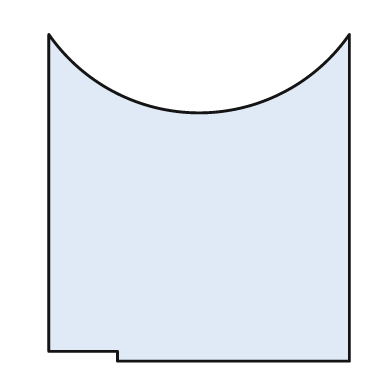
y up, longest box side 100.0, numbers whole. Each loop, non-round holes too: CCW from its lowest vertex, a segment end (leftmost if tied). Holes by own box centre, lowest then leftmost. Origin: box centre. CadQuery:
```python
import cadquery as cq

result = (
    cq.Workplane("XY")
    .moveTo(-25.0, -50.0)
    .lineTo(46.0, -50.0)
    .lineTo(46.0, 50.0)
    .threePointArc((0.0, 26.0), (-46.0, 50.0))
    .lineTo(-46.0, -47.0)
    .lineTo(-25.0, -47.0)
    .close()
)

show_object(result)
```